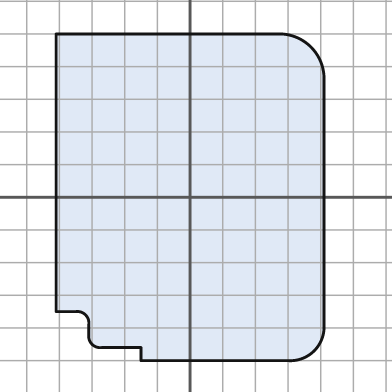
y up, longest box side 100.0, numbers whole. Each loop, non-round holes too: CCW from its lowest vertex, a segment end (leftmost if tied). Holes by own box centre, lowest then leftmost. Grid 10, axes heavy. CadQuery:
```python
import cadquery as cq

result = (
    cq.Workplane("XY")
    .moveTo(-15.0, -50.0)
    .lineTo(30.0, -50.0)
    .threePointArc((38.0, -47.0), (41.0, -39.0))
    .lineTo(41.0, 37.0)
    .threePointArc((37.0, 46.0), (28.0, 50.0))
    .lineTo(-41.0, 50.0)
    .lineTo(-41.0, -35.0)
    .lineTo(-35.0, -35.0)
    .threePointArc((-32.0, -36.0), (-31.0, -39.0))
    .lineTo(-31.0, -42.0)
    .threePointArc((-30.0, -45.0), (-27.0, -46.0))
    .lineTo(-15.0, -46.0)
    .close()
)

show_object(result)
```